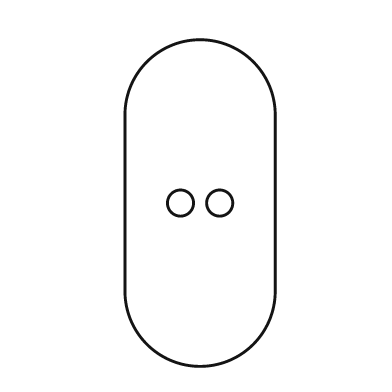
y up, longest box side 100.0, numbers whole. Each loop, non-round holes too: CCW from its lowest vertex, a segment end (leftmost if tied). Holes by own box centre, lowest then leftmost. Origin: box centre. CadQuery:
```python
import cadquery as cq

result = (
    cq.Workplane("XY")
    .moveTo(-23.0, -27.0)
    .threePointArc((0.0, -50.0), (23.0, -27.0))
    .lineTo(23.0, 27.0)
    .threePointArc((0.0, 50.0), (-23.0, 27.0))
    .close()
    .moveTo(-6.0, 0.0)
    .circle(4.0)
    .moveTo(6.0, 0.0)
    .circle(4.0)
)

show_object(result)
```